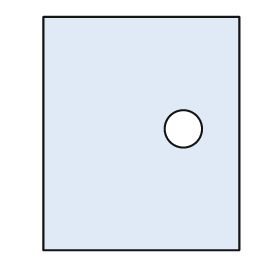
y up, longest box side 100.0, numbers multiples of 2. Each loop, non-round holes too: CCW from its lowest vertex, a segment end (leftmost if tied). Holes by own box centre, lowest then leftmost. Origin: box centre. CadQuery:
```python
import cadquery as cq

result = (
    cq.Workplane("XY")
    .moveTo(-42.0, -50.0)
    .lineTo(42.0, -50.0)
    .lineTo(42.0, 50.0)
    .lineTo(-42.0, 50.0)
    .close()
    .moveTo(18.0, 2.0)
    .circle(8.0)
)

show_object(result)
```